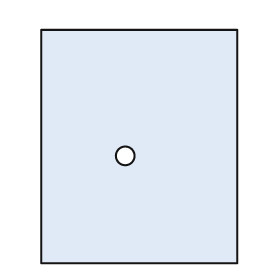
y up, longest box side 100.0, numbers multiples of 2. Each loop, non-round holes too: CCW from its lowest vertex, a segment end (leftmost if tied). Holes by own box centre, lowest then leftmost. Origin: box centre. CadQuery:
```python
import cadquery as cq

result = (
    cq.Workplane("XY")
    .moveTo(-42.0, -50.0)
    .lineTo(42.0, -50.0)
    .lineTo(42.0, 50.0)
    .lineTo(-42.0, 50.0)
    .close()
    .moveTo(-6.0, -4.0)
    .circle(4.0)
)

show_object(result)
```